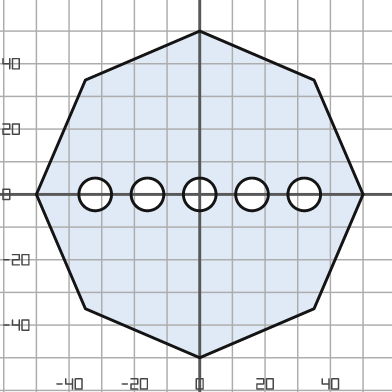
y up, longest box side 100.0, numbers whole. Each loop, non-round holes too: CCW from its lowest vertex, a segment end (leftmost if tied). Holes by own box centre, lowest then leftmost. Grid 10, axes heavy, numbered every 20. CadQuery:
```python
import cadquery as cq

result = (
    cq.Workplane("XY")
    .moveTo(0.0, -50.0)
    .lineTo(35.0, -35.0)
    .lineTo(50.0, 0.0)
    .lineTo(35.0, 35.0)
    .lineTo(0.0, 50.0)
    .lineTo(-35.0, 35.0)
    .lineTo(-50.0, 0.0)
    .lineTo(-35.0, -35.0)
    .close()
    .moveTo(-32.0, 0.0)
    .circle(5.0)
    .moveTo(-16.0, 0.0)
    .circle(5.0)
    .moveTo(0.0, 0.0)
    .circle(5.0)
    .moveTo(16.0, 0.0)
    .circle(5.0)
    .moveTo(32.0, 0.0)
    .circle(5.0)
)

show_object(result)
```